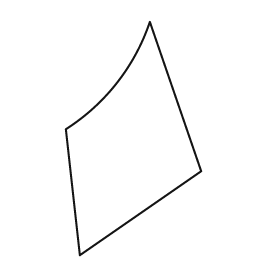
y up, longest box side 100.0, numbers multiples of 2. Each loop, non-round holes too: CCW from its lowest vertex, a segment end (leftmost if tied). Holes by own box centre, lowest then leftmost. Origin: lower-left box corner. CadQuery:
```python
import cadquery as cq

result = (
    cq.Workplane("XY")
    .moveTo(6.0, 0.0)
    .lineTo(58.0, 36.0)
    .lineTo(36.0, 100.0)
    .threePointArc((22.0, 74.0), (0.0, 54.0))
    .close()
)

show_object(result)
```